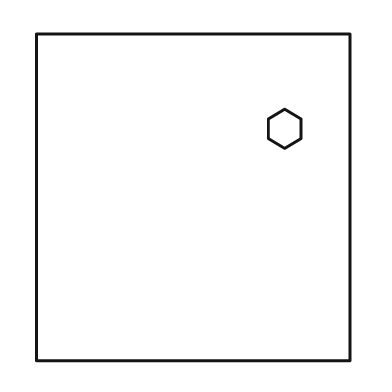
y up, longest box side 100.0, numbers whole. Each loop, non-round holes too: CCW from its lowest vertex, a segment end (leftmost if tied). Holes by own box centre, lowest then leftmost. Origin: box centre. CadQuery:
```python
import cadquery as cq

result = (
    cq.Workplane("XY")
    .moveTo(-48.0, -50.0)
    .lineTo(48.0, -50.0)
    .lineTo(48.0, 50.0)
    .lineTo(-48.0, 50.0)
    .close()
    .moveTo(28.0, 15.0)
    .lineTo(33.0, 18.0)
    .lineTo(33.0, 24.0)
    .lineTo(28.0, 27.0)
    .lineTo(23.0, 24.0)
    .lineTo(23.0, 18.0)
    .close()
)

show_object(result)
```